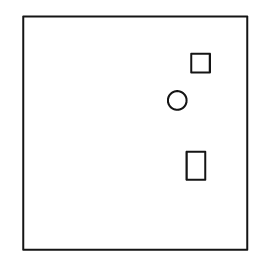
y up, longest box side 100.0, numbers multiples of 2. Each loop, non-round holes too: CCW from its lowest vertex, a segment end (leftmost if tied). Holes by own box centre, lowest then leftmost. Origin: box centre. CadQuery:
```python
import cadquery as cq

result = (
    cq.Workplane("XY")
    .moveTo(-48.0, -50.0)
    .lineTo(48.0, -50.0)
    .lineTo(48.0, 50.0)
    .lineTo(-48.0, 50.0)
    .close()
    .moveTo(22.0, -20.0)
    .lineTo(30.0, -20.0)
    .lineTo(30.0, -8.0)
    .lineTo(22.0, -8.0)
    .close()
    .moveTo(18.0, 14.0)
    .circle(4.0)
    .moveTo(24.0, 26.0)
    .lineTo(32.0, 26.0)
    .lineTo(32.0, 34.0)
    .lineTo(24.0, 34.0)
    .close()
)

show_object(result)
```